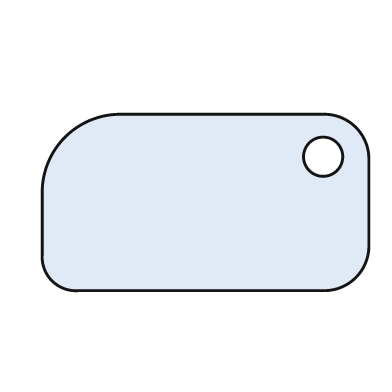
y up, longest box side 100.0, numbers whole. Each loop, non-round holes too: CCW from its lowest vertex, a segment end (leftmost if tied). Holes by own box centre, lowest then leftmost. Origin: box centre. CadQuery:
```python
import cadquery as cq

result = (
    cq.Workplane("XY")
    .moveTo(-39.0, -27.0)
    .lineTo(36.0, -27.0)
    .threePointArc((46.0, -23.0), (50.0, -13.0))
    .lineTo(50.0, 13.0)
    .threePointArc((46.0, 23.0), (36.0, 27.0))
    .lineTo(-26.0, 27.0)
    .threePointArc((-43.0, 20.0), (-50.0, 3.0))
    .lineTo(-50.0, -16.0)
    .threePointArc((-47.0, -24.0), (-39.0, -27.0))
    .close()
    .moveTo(36.0, 14.0)
    .circle(6.0)
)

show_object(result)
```